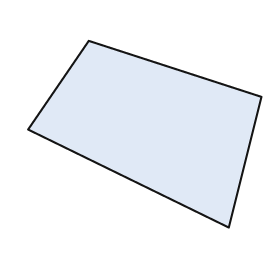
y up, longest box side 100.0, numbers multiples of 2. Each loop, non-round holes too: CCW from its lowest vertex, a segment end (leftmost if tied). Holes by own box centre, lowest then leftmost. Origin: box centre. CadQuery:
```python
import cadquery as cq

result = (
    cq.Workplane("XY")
    .moveTo(36.0, -40.0)
    .lineTo(50.0, 16.0)
    .lineTo(-24.0, 40.0)
    .lineTo(-50.0, 2.0)
    .close()
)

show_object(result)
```